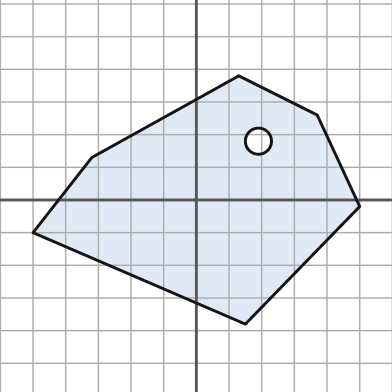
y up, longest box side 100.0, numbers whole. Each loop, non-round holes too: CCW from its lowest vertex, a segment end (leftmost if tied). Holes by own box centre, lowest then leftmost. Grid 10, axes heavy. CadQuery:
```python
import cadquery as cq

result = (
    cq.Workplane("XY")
    .moveTo(15.0, -38.0)
    .lineTo(50.0, -2.0)
    .lineTo(37.0, 26.0)
    .lineTo(13.0, 38.0)
    .lineTo(-32.0, 13.0)
    .lineTo(-50.0, -10.0)
    .close()
    .moveTo(19.0, 18.0)
    .circle(4.0)
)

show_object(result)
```